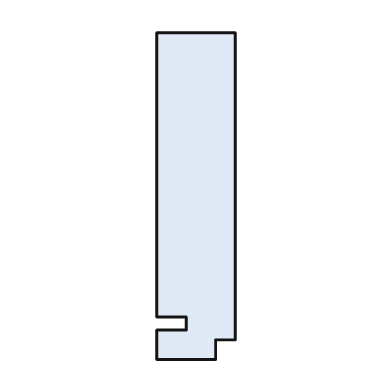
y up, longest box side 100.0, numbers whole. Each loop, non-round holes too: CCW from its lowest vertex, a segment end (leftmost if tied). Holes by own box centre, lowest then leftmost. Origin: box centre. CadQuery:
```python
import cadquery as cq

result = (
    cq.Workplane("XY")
    .moveTo(-12.0, -50.0)
    .lineTo(6.0, -50.0)
    .lineTo(6.0, -44.0)
    .lineTo(12.0, -44.0)
    .lineTo(12.0, 50.0)
    .lineTo(-12.0, 50.0)
    .lineTo(-12.0, -37.0)
    .lineTo(-3.0, -37.0)
    .lineTo(-3.0, -41.0)
    .lineTo(-12.0, -41.0)
    .close()
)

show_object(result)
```